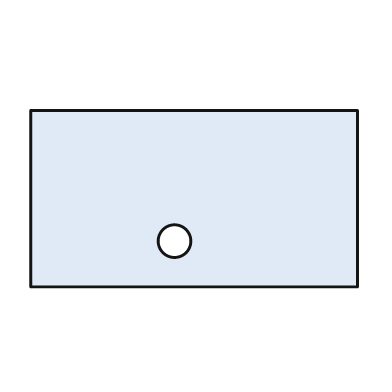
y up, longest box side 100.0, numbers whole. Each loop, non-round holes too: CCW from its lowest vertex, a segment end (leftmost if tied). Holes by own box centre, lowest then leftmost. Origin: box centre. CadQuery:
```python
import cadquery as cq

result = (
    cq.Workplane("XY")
    .moveTo(-50.0, -27.0)
    .lineTo(50.0, -27.0)
    .lineTo(50.0, 27.0)
    .lineTo(-50.0, 27.0)
    .close()
    .moveTo(-6.0, -13.0)
    .circle(5.0)
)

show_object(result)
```